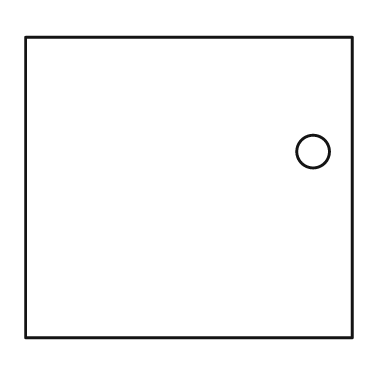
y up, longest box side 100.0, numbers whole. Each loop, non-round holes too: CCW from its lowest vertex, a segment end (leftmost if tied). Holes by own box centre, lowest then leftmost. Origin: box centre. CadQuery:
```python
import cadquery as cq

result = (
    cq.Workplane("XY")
    .moveTo(-50.0, -46.0)
    .lineTo(50.0, -46.0)
    .lineTo(50.0, 46.0)
    .lineTo(-50.0, 46.0)
    .close()
    .moveTo(38.0, 11.0)
    .circle(5.0)
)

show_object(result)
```